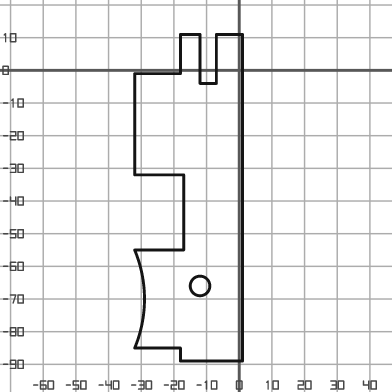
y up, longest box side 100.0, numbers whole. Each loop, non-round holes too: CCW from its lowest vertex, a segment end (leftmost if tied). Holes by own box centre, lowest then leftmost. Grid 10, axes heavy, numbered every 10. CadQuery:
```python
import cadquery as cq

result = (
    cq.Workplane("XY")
    .moveTo(-18.0, -89.0)
    .lineTo(1.0, -89.0)
    .lineTo(1.0, 11.0)
    .lineTo(-7.0, 11.0)
    .lineTo(-7.0, -4.0)
    .lineTo(-12.0, -4.0)
    .lineTo(-12.0, 11.0)
    .lineTo(-18.0, 11.0)
    .lineTo(-18.0, -1.0)
    .lineTo(-32.0, -1.0)
    .lineTo(-32.0, -32.0)
    .lineTo(-17.0, -32.0)
    .lineTo(-17.0, -55.0)
    .lineTo(-32.0, -55.0)
    .threePointArc((-29.0, -70.0), (-32.0, -85.0))
    .lineTo(-18.0, -85.0)
    .close()
    .moveTo(-12.0, -66.0)
    .circle(3.0)
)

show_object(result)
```